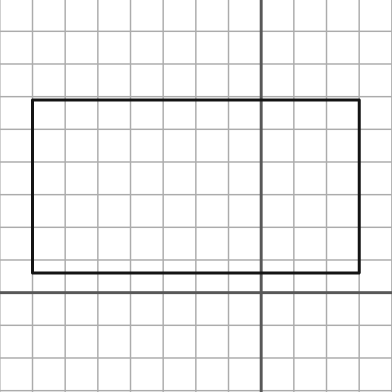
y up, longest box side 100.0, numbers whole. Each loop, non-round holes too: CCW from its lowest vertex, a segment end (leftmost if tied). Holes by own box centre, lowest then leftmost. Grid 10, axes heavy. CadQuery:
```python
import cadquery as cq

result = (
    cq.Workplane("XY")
    .moveTo(-70.0, 6.0)
    .lineTo(30.0, 6.0)
    .lineTo(30.0, 59.0)
    .lineTo(-70.0, 59.0)
    .close()
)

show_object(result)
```